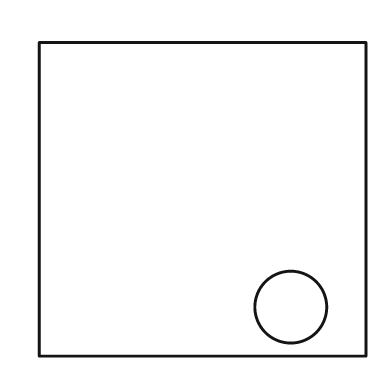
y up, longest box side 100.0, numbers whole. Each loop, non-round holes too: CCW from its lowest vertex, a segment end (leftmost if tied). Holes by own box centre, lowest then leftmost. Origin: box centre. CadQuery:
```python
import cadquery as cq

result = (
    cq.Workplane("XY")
    .moveTo(-50.0, -48.0)
    .lineTo(50.0, -48.0)
    .lineTo(50.0, 48.0)
    .lineTo(-50.0, 48.0)
    .close()
    .moveTo(27.0, -33.0)
    .circle(11.0)
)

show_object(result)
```